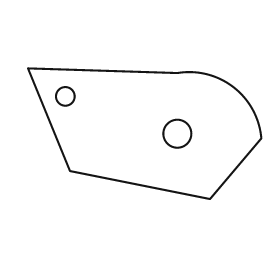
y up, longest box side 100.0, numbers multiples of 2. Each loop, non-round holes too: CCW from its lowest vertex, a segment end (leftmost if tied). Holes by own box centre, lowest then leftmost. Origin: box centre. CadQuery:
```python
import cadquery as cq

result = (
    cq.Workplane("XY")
    .moveTo(28.0, -28.0)
    .lineTo(50.0, -2.0)
    .threePointArc((38.0, 20.0), (14.0, 26.0))
    .lineTo(-50.0, 28.0)
    .lineTo(-32.0, -16.0)
    .close()
    .moveTo(14.0, 0.0)
    .circle(6.0)
    .moveTo(-34.0, 16.0)
    .circle(4.0)
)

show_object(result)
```